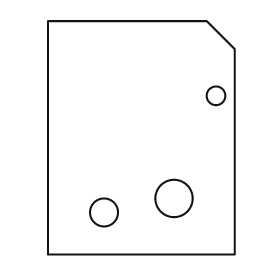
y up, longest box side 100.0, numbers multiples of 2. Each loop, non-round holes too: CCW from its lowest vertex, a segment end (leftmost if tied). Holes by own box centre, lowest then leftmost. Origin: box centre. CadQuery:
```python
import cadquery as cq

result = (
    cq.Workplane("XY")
    .moveTo(-40.0, -50.0)
    .lineTo(40.0, -50.0)
    .lineTo(40.0, 38.0)
    .lineTo(28.0, 50.0)
    .lineTo(-40.0, 50.0)
    .close()
    .moveTo(-16.0, -32.0)
    .circle(6.0)
    .moveTo(14.0, -26.0)
    .circle(8.0)
    .moveTo(32.0, 18.0)
    .circle(4.0)
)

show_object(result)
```